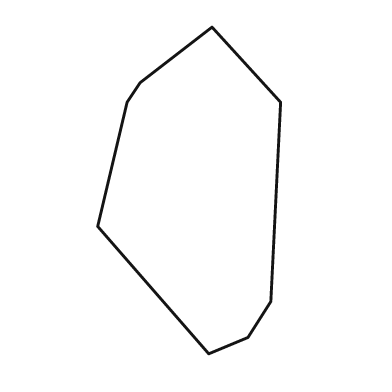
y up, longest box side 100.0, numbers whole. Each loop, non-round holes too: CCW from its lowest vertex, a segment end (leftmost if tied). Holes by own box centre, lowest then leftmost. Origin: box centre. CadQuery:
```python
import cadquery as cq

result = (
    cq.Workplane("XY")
    .moveTo(6.0, -50.0)
    .lineTo(18.0, -45.0)
    .lineTo(25.0, -34.0)
    .lineTo(28.0, 27.0)
    .lineTo(7.0, 50.0)
    .lineTo(-15.0, 33.0)
    .lineTo(-19.0, 27.0)
    .lineTo(-28.0, -11.0)
    .close()
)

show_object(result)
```